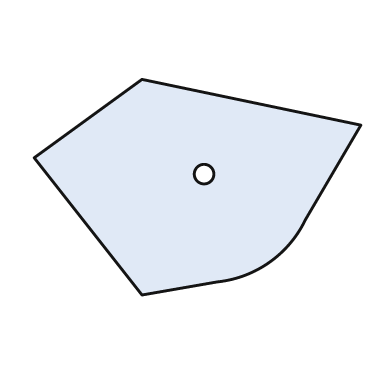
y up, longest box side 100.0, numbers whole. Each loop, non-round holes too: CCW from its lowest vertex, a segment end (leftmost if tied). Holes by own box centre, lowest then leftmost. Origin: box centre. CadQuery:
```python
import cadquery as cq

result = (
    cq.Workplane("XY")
    .moveTo(-17.0, -33.0)
    .lineTo(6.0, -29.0)
    .threePointArc((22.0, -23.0), (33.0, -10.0))
    .lineTo(50.0, 19.0)
    .lineTo(-17.0, 33.0)
    .lineTo(-50.0, 9.0)
    .close()
    .moveTo(2.0, 4.0)
    .circle(3.0)
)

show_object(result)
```